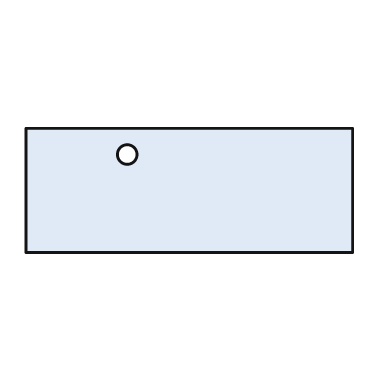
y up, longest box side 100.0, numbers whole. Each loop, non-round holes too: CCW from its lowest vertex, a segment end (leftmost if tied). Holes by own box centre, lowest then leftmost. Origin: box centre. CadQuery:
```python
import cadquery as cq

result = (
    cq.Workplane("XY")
    .moveTo(-50.0, -19.0)
    .lineTo(50.0, -19.0)
    .lineTo(50.0, 19.0)
    .lineTo(-50.0, 19.0)
    .close()
    .moveTo(-19.0, 11.0)
    .circle(3.0)
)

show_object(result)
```